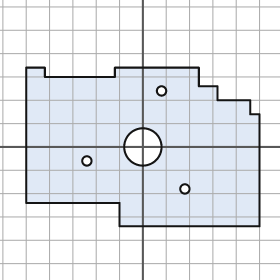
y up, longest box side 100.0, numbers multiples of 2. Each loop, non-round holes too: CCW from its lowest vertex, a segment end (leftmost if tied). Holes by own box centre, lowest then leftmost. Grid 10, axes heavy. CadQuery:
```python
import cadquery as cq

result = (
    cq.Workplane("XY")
    .moveTo(-10.0, -34.0)
    .lineTo(50.0, -34.0)
    .lineTo(50.0, 14.0)
    .lineTo(46.0, 14.0)
    .lineTo(46.0, 20.0)
    .lineTo(32.0, 20.0)
    .lineTo(32.0, 26.0)
    .lineTo(24.0, 26.0)
    .lineTo(24.0, 34.0)
    .lineTo(-12.0, 34.0)
    .lineTo(-12.0, 30.0)
    .lineTo(-42.0, 30.0)
    .lineTo(-42.0, 34.0)
    .lineTo(-50.0, 34.0)
    .lineTo(-50.0, -24.0)
    .lineTo(-10.0, -24.0)
    .close()
    .moveTo(18.0, -18.0)
    .circle(2.0)
    .moveTo(-24.0, -6.0)
    .circle(2.0)
    .moveTo(0.0, 0.0)
    .circle(8.0)
    .moveTo(8.0, 24.0)
    .circle(2.0)
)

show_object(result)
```